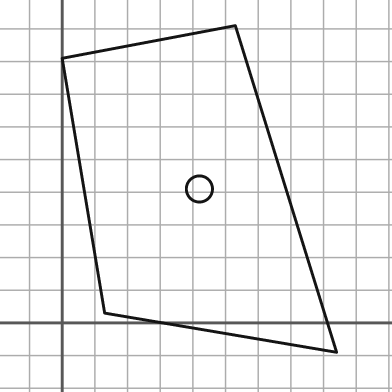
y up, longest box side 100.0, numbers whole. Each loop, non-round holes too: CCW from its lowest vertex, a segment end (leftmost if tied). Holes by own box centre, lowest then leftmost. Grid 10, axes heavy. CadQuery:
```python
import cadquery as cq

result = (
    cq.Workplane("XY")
    .moveTo(84.0, -9.0)
    .lineTo(53.0, 91.0)
    .lineTo(0.0, 81.0)
    .lineTo(13.0, 3.0)
    .close()
    .moveTo(42.0, 41.0)
    .circle(4.0)
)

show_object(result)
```